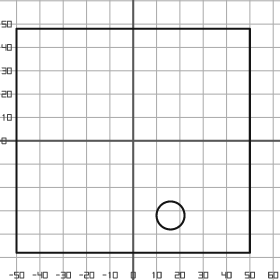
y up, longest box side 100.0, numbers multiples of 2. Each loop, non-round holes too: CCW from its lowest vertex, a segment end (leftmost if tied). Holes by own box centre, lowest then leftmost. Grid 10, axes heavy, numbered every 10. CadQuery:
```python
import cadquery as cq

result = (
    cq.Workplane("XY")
    .moveTo(-50.0, -48.0)
    .lineTo(50.0, -48.0)
    .lineTo(50.0, 48.0)
    .lineTo(-50.0, 48.0)
    .close()
    .moveTo(16.0, -32.0)
    .circle(6.0)
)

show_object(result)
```